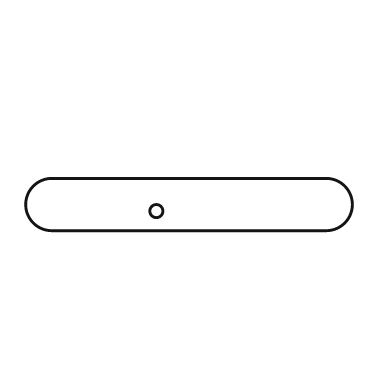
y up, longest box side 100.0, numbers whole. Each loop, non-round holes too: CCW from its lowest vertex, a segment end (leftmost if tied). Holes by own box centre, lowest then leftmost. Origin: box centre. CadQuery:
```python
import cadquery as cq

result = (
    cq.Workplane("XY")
    .moveTo(-42.0, -8.0)
    .lineTo(42.0, -8.0)
    .threePointArc((50.0, 0.0), (42.0, 8.0))
    .lineTo(-42.0, 8.0)
    .threePointArc((-50.0, 0.0), (-42.0, -8.0))
    .close()
    .moveTo(-10.0, -2.0)
    .circle(2.0)
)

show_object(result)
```